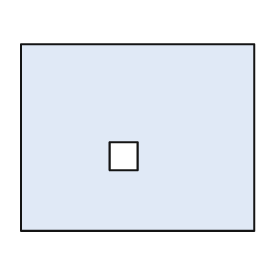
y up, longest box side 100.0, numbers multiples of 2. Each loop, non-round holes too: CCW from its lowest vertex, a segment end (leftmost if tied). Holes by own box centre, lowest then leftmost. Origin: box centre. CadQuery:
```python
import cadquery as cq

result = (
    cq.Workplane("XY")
    .moveTo(-50.0, -40.0)
    .lineTo(50.0, -40.0)
    .lineTo(50.0, 40.0)
    .lineTo(-50.0, 40.0)
    .close()
    .moveTo(-12.0, -14.0)
    .lineTo(0.0, -14.0)
    .lineTo(0.0, -2.0)
    .lineTo(-12.0, -2.0)
    .close()
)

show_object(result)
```